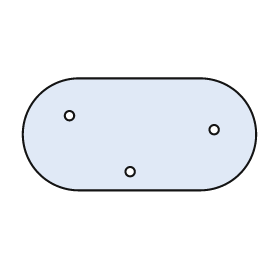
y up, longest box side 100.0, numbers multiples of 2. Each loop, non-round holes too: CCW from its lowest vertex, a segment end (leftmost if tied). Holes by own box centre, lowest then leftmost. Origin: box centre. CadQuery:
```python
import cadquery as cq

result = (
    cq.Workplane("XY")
    .moveTo(-26.0, -24.0)
    .lineTo(26.0, -24.0)
    .threePointArc((50.0, 0.0), (26.0, 24.0))
    .lineTo(-26.0, 24.0)
    .threePointArc((-50.0, 0.0), (-26.0, -24.0))
    .close()
    .moveTo(-4.0, -16.0)
    .circle(2.0)
    .moveTo(32.0, 2.0)
    .circle(2.0)
    .moveTo(-30.0, 8.0)
    .circle(2.0)
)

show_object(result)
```